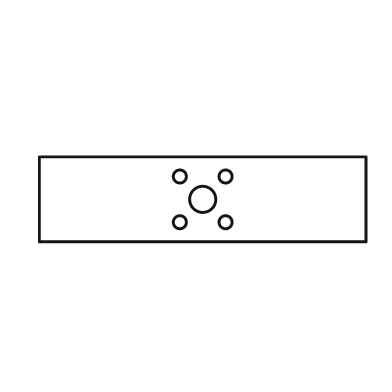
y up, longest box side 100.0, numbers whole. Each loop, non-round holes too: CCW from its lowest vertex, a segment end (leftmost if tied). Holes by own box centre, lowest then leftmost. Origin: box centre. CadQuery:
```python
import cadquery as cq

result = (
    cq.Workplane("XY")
    .moveTo(-50.0, -13.0)
    .lineTo(50.0, -13.0)
    .lineTo(50.0, 13.0)
    .lineTo(-50.0, 13.0)
    .close()
    .moveTo(-7.0, -7.0)
    .circle(2.0)
    .moveTo(7.0, -7.0)
    .circle(2.0)
    .moveTo(0.0, 0.0)
    .circle(4.0)
    .moveTo(-7.0, 7.0)
    .circle(2.0)
    .moveTo(7.0, 7.0)
    .circle(2.0)
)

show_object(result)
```